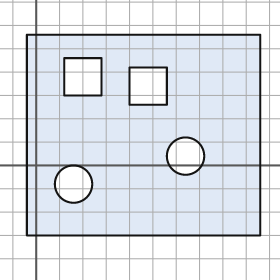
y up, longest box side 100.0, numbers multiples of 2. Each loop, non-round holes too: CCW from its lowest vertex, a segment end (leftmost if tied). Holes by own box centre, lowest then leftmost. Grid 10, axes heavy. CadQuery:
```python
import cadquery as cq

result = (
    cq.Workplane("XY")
    .moveTo(-4.0, -30.0)
    .lineTo(96.0, -30.0)
    .lineTo(96.0, 56.0)
    .lineTo(-4.0, 56.0)
    .close()
    .moveTo(16.0, -8.0)
    .circle(8.0)
    .moveTo(64.0, 4.0)
    .circle(8.0)
    .moveTo(40.0, 26.0)
    .lineTo(56.0, 26.0)
    .lineTo(56.0, 42.0)
    .lineTo(40.0, 42.0)
    .close()
    .moveTo(12.0, 30.0)
    .lineTo(28.0, 30.0)
    .lineTo(28.0, 46.0)
    .lineTo(12.0, 46.0)
    .close()
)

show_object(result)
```